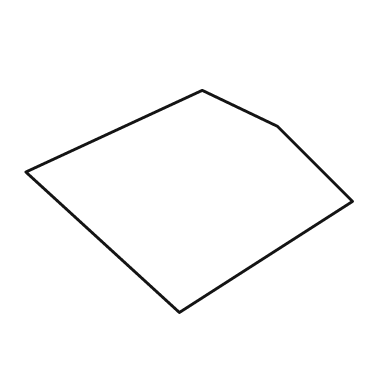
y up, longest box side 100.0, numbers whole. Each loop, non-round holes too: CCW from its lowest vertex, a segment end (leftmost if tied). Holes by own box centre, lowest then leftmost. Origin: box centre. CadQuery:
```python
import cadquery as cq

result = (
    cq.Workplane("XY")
    .moveTo(-3.0, -34.0)
    .lineTo(50.0, 0.0)
    .lineTo(27.0, 23.0)
    .lineTo(4.0, 34.0)
    .lineTo(-50.0, 9.0)
    .close()
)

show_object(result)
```